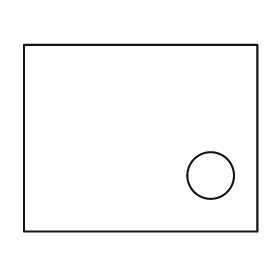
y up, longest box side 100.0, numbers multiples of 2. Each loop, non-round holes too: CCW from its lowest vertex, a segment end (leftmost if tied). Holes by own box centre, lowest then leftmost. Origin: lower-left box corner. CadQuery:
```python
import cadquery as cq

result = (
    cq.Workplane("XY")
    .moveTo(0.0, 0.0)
    .lineTo(100.0, 0.0)
    .lineTo(100.0, 80.0)
    .lineTo(0.0, 80.0)
    .close()
    .moveTo(80.0, 24.0)
    .circle(10.0)
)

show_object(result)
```